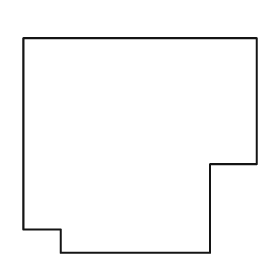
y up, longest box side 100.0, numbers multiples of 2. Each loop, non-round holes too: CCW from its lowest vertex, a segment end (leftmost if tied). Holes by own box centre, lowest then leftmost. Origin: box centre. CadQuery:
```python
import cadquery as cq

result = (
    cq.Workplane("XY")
    .moveTo(-34.0, -46.0)
    .lineTo(30.0, -46.0)
    .lineTo(30.0, -8.0)
    .lineTo(50.0, -8.0)
    .lineTo(50.0, 46.0)
    .lineTo(-50.0, 46.0)
    .lineTo(-50.0, -36.0)
    .lineTo(-34.0, -36.0)
    .close()
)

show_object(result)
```